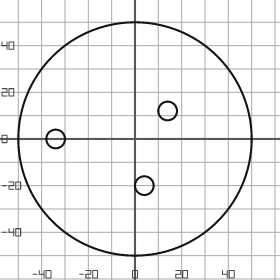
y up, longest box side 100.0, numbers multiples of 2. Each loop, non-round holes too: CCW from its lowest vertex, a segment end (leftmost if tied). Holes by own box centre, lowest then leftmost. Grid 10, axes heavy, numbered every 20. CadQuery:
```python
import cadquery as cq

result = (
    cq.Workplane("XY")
    .moveTo(0.0, 0.0)
    .circle(50.0)
    .moveTo(4.0, -20.0)
    .circle(4.0)
    .moveTo(-34.0, 0.0)
    .circle(4.0)
    .moveTo(14.0, 12.0)
    .circle(4.0)
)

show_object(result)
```